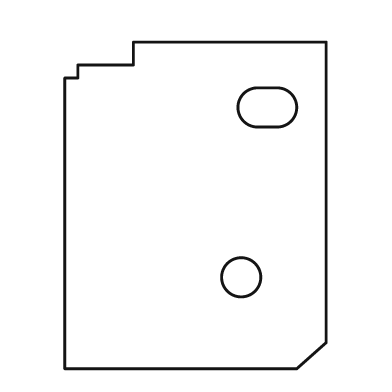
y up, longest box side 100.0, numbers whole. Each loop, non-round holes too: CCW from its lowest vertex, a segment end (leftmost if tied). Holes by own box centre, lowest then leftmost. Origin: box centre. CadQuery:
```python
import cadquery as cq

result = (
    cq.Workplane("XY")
    .moveTo(-40.0, -50.0)
    .lineTo(31.0, -50.0)
    .lineTo(40.0, -42.0)
    .lineTo(40.0, 50.0)
    .lineTo(-19.0, 50.0)
    .lineTo(-19.0, 43.0)
    .lineTo(-36.0, 43.0)
    .lineTo(-36.0, 39.0)
    .lineTo(-40.0, 39.0)
    .close()
    .moveTo(14.0, -22.0)
    .circle(6.0)
    .moveTo(19.0, 24.0)
    .lineTo(25.0, 24.0)
    .threePointArc((31.0, 30.0), (25.0, 36.0))
    .lineTo(19.0, 36.0)
    .threePointArc((13.0, 30.0), (19.0, 24.0))
    .close()
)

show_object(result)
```